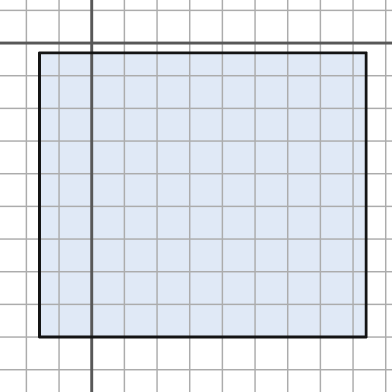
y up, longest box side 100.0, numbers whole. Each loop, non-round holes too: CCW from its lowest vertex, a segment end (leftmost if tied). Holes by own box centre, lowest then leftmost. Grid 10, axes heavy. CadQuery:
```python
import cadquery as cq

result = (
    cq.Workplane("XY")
    .moveTo(-16.0, -90.0)
    .lineTo(84.0, -90.0)
    .lineTo(84.0, -3.0)
    .lineTo(-16.0, -3.0)
    .close()
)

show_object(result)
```